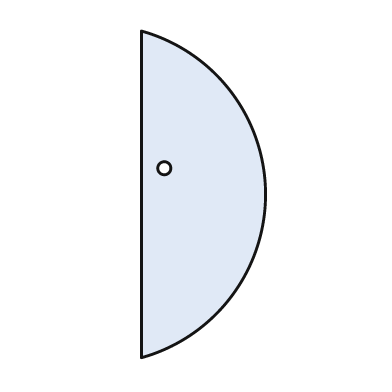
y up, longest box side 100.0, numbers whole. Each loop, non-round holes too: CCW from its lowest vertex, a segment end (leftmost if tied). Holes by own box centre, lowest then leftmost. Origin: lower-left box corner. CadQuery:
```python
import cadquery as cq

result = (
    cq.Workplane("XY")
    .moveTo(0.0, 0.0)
    .threePointArc((38.0, 50.0), (0.0, 100.0))
    .close()
    .moveTo(7.0, 58.0)
    .circle(2.0)
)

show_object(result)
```